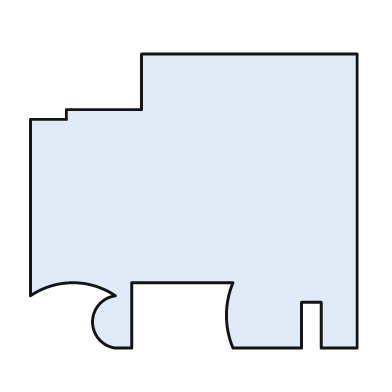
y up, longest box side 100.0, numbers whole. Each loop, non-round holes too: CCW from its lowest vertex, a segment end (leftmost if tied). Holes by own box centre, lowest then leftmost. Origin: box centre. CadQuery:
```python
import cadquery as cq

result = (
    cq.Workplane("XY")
    .moveTo(-24.0, -45.0)
    .lineTo(-19.0, -45.0)
    .lineTo(-19.0, -25.0)
    .lineTo(12.0, -25.0)
    .threePointArc((10.0, -35.0), (12.0, -45.0))
    .lineTo(33.0, -45.0)
    .lineTo(33.0, -31.0)
    .lineTo(39.0, -31.0)
    .lineTo(39.0, -45.0)
    .lineTo(50.0, -45.0)
    .lineTo(50.0, 45.0)
    .lineTo(-16.0, 45.0)
    .lineTo(-16.0, 28.0)
    .lineTo(-39.0, 28.0)
    .lineTo(-39.0, 25.0)
    .lineTo(-50.0, 25.0)
    .lineTo(-50.0, -29.0)
    .threePointArc((-37.0, -25.0), (-24.0, -29.0))
    .threePointArc((-31.0, -37.0), (-24.0, -45.0))
    .close()
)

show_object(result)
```